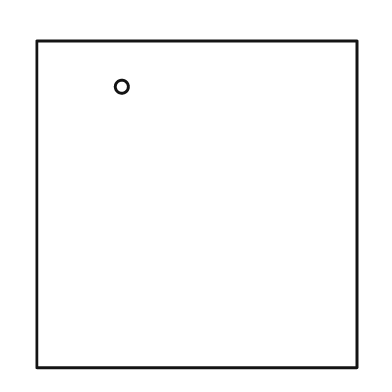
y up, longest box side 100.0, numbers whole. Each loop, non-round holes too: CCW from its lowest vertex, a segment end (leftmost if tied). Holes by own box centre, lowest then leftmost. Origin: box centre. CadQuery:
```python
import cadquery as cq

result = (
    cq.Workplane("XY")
    .moveTo(-49.0, -50.0)
    .lineTo(49.0, -50.0)
    .lineTo(49.0, 50.0)
    .lineTo(-49.0, 50.0)
    .close()
    .moveTo(-23.0, 36.0)
    .circle(2.0)
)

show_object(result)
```